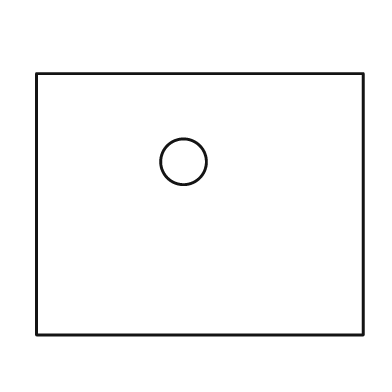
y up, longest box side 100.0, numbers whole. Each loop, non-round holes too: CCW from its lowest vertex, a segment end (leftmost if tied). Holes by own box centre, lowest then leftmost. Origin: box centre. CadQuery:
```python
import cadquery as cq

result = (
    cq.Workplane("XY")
    .moveTo(-50.0, -40.0)
    .lineTo(50.0, -40.0)
    .lineTo(50.0, 40.0)
    .lineTo(-50.0, 40.0)
    .close()
    .moveTo(-5.0, 13.0)
    .circle(7.0)
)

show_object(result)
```